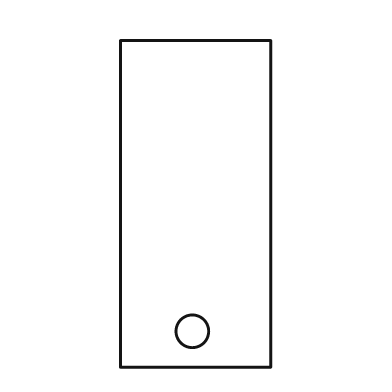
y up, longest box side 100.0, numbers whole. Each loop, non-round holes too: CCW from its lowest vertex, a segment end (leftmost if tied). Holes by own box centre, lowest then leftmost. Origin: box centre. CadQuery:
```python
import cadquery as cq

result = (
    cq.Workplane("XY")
    .moveTo(-23.0, -50.0)
    .lineTo(23.0, -50.0)
    .lineTo(23.0, 50.0)
    .lineTo(-23.0, 50.0)
    .close()
    .moveTo(-1.0, -39.0)
    .circle(5.0)
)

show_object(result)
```